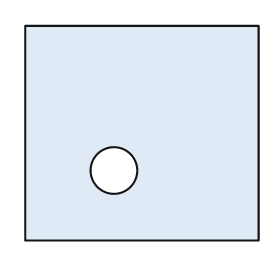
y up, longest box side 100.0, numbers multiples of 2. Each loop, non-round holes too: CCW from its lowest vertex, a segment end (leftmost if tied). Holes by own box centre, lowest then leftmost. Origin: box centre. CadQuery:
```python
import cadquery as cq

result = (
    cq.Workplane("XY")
    .moveTo(-50.0, -46.0)
    .lineTo(50.0, -46.0)
    .lineTo(50.0, 46.0)
    .lineTo(-50.0, 46.0)
    .close()
    .moveTo(-12.0, -16.0)
    .circle(10.0)
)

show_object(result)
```